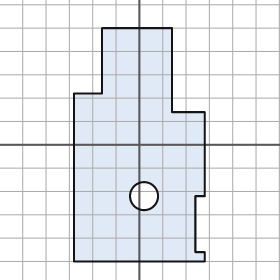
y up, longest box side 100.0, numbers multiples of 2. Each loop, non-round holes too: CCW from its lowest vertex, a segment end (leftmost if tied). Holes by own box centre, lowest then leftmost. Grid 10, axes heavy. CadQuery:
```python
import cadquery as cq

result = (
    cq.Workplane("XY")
    .moveTo(-28.0, -50.0)
    .lineTo(28.0, -50.0)
    .lineTo(28.0, -46.0)
    .lineTo(24.0, -46.0)
    .lineTo(24.0, -22.0)
    .lineTo(28.0, -22.0)
    .lineTo(28.0, 14.0)
    .lineTo(14.0, 14.0)
    .lineTo(14.0, 50.0)
    .lineTo(-16.0, 50.0)
    .lineTo(-16.0, 22.0)
    .lineTo(-28.0, 22.0)
    .close()
    .moveTo(2.0, -22.0)
    .circle(6.0)
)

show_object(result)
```